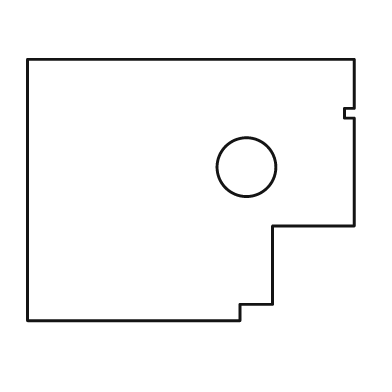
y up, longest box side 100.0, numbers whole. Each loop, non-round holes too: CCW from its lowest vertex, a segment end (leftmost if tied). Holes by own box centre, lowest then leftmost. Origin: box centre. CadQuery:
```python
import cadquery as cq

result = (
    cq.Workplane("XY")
    .moveTo(-50.0, -40.0)
    .lineTo(15.0, -40.0)
    .lineTo(15.0, -35.0)
    .lineTo(25.0, -35.0)
    .lineTo(25.0, -11.0)
    .lineTo(50.0, -11.0)
    .lineTo(50.0, 22.0)
    .lineTo(47.0, 22.0)
    .lineTo(47.0, 25.0)
    .lineTo(50.0, 25.0)
    .lineTo(50.0, 40.0)
    .lineTo(-50.0, 40.0)
    .close()
    .moveTo(17.0, 7.0)
    .circle(9.0)
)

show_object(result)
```